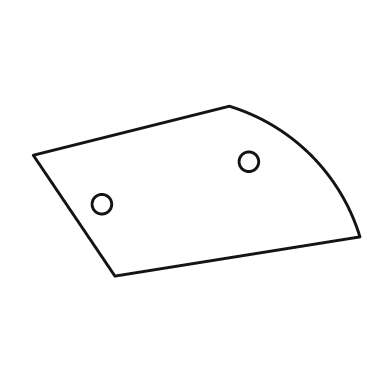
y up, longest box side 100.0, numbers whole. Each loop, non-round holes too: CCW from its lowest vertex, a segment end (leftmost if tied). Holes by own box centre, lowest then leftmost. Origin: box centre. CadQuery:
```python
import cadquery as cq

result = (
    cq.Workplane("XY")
    .moveTo(-25.0, -26.0)
    .lineTo(50.0, -14.0)
    .threePointArc((35.0, 11.0), (10.0, 26.0))
    .lineTo(-50.0, 11.0)
    .close()
    .moveTo(-29.0, -4.0)
    .circle(3.0)
    .moveTo(16.0, 9.0)
    .circle(3.0)
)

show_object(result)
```